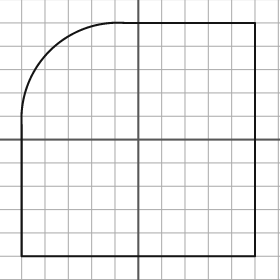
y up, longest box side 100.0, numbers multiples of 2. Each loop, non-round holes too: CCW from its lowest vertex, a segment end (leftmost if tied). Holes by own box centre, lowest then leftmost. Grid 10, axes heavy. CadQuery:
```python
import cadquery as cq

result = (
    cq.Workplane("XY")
    .moveTo(-50.0, -50.0)
    .lineTo(50.0, -50.0)
    .lineTo(50.0, 50.0)
    .lineTo(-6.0, 50.0)
    .threePointArc((-38.0, 38.0), (-50.0, 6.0))
    .close()
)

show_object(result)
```